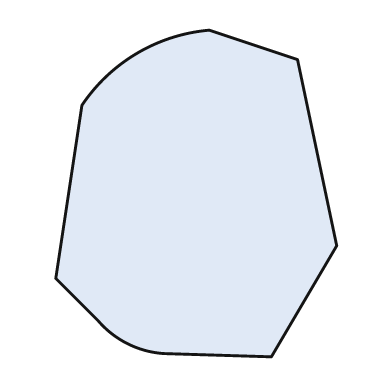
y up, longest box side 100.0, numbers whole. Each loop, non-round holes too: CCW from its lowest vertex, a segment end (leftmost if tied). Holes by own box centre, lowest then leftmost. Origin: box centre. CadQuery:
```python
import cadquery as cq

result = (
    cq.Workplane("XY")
    .moveTo(23.0, -50.0)
    .lineTo(43.0, -16.0)
    .lineTo(31.0, 41.0)
    .lineTo(4.0, 50.0)
    .threePointArc((-18.0, 43.0), (-35.0, 27.0))
    .lineTo(-43.0, -26.0)
    .lineTo(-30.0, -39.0)
    .threePointArc((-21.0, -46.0), (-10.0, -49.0))
    .close()
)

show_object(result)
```